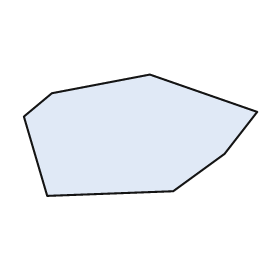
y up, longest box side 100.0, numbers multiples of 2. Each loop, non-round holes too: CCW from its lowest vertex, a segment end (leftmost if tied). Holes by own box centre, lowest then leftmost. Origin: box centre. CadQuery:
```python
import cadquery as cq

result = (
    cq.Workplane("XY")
    .moveTo(-40.0, -26.0)
    .lineTo(14.0, -24.0)
    .lineTo(36.0, -8.0)
    .lineTo(50.0, 10.0)
    .lineTo(4.0, 26.0)
    .lineTo(-38.0, 18.0)
    .lineTo(-50.0, 8.0)
    .close()
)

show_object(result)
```